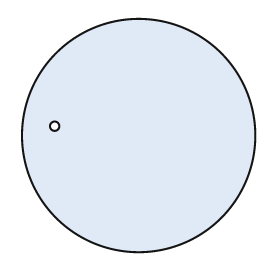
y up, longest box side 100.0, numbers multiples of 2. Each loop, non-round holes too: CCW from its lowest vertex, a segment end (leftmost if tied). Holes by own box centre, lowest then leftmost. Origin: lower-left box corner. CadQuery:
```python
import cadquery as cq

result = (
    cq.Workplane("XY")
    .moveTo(50.0, 50.0)
    .circle(50.0)
    .moveTo(14.0, 54.0)
    .circle(2.0)
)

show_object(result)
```